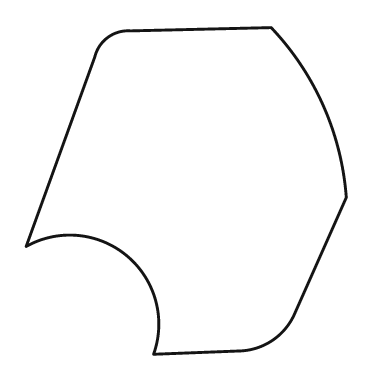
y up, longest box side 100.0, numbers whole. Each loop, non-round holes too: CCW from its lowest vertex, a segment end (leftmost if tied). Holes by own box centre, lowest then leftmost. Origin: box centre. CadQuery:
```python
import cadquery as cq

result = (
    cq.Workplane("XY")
    .moveTo(-10.0, -50.0)
    .lineTo(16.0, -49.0)
    .threePointArc((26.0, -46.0), (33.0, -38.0))
    .lineTo(49.0, -2.0)
    .threePointArc((42.0, 26.0), (26.0, 50.0))
    .lineTo(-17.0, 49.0)
    .threePointArc((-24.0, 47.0), (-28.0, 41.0))
    .lineTo(-49.0, -17.0)
    .threePointArc((-18.0, -20.0), (-10.0, -50.0))
    .close()
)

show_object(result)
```